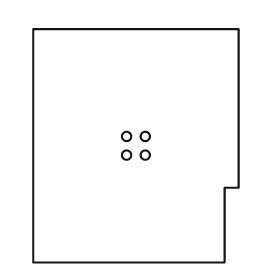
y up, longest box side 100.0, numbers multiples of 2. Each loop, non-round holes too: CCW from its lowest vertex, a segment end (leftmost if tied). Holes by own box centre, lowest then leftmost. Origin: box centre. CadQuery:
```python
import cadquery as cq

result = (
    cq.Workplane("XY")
    .moveTo(-44.0, -50.0)
    .lineTo(38.0, -50.0)
    .lineTo(38.0, -18.0)
    .lineTo(44.0, -18.0)
    .lineTo(44.0, 50.0)
    .lineTo(-44.0, 50.0)
    .close()
    .moveTo(-4.0, -4.0)
    .circle(2.0)
    .moveTo(4.0, -4.0)
    .circle(2.0)
    .moveTo(-4.0, 4.0)
    .circle(2.0)
    .moveTo(4.0, 4.0)
    .circle(2.0)
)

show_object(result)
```